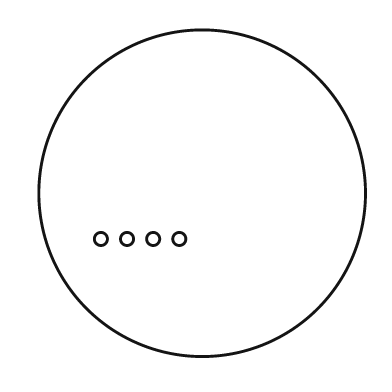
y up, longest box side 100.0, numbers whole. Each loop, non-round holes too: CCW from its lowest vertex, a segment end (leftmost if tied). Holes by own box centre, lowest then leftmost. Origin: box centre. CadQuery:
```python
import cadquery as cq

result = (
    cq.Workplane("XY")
    .moveTo(0.0, 0.0)
    .circle(50.0)
    .moveTo(-31.0, -14.0)
    .circle(2.0)
    .moveTo(-23.0, -14.0)
    .circle(2.0)
    .moveTo(-15.0, -14.0)
    .circle(2.0)
    .moveTo(-7.0, -14.0)
    .circle(2.0)
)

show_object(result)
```